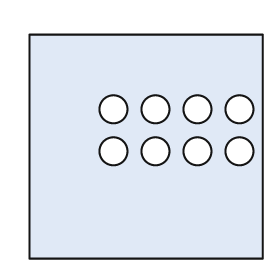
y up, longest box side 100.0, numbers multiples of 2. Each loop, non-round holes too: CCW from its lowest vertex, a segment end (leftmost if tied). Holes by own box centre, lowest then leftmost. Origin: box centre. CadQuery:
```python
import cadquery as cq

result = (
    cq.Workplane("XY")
    .moveTo(-50.0, -48.0)
    .lineTo(50.0, -48.0)
    .lineTo(50.0, 48.0)
    .lineTo(-50.0, 48.0)
    .close()
    .moveTo(-14.0, -2.0)
    .circle(6.0)
    .moveTo(4.0, -2.0)
    .circle(6.0)
    .moveTo(22.0, -2.0)
    .circle(6.0)
    .moveTo(40.0, -2.0)
    .circle(6.0)
    .moveTo(-14.0, 16.0)
    .circle(6.0)
    .moveTo(4.0, 16.0)
    .circle(6.0)
    .moveTo(22.0, 16.0)
    .circle(6.0)
    .moveTo(40.0, 16.0)
    .circle(6.0)
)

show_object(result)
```